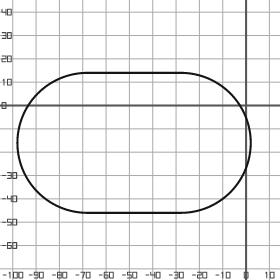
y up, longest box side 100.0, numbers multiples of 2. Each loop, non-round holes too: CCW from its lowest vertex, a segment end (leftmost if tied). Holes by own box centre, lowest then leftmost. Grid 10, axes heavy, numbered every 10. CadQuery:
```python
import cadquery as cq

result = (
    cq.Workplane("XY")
    .moveTo(-68.0, -46.0)
    .lineTo(-28.0, -46.0)
    .threePointArc((2.0, -16.0), (-28.0, 14.0))
    .lineTo(-68.0, 14.0)
    .threePointArc((-98.0, -16.0), (-68.0, -46.0))
    .close()
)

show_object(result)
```